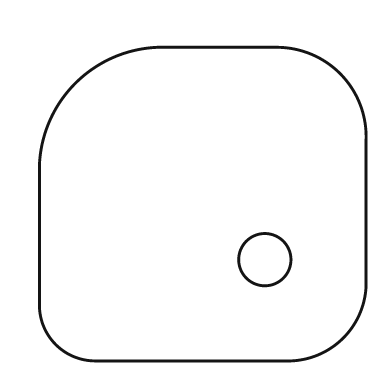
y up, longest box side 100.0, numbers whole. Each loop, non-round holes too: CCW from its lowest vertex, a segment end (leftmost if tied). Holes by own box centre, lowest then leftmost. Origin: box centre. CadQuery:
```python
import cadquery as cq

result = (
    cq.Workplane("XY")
    .moveTo(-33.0, -48.0)
    .lineTo(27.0, -48.0)
    .threePointArc((43.0, -41.0), (50.0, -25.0))
    .lineTo(50.0, 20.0)
    .threePointArc((42.0, 40.0), (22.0, 48.0))
    .lineTo(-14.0, 48.0)
    .threePointArc((-39.0, 37.0), (-50.0, 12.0))
    .lineTo(-50.0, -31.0)
    .threePointArc((-45.0, -43.0), (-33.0, -48.0))
    .close()
    .moveTo(19.0, -17.0)
    .circle(8.0)
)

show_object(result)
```